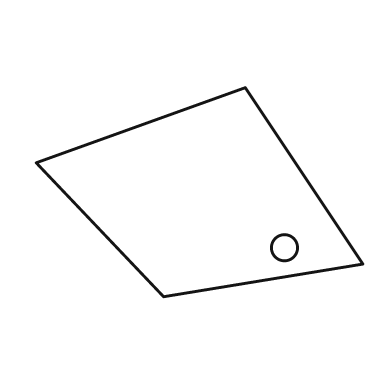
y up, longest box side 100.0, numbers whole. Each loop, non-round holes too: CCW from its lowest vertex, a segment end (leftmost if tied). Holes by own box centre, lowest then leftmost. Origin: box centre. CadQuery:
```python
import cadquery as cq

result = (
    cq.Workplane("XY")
    .moveTo(-11.0, -32.0)
    .lineTo(50.0, -22.0)
    .lineTo(14.0, 32.0)
    .lineTo(-50.0, 9.0)
    .close()
    .moveTo(26.0, -17.0)
    .circle(4.0)
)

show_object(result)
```